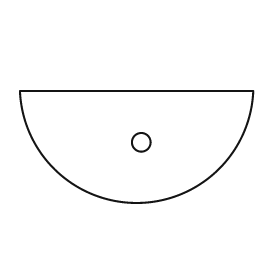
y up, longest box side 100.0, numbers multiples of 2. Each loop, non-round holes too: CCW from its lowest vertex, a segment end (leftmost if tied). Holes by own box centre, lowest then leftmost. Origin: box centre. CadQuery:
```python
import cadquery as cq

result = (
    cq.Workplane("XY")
    .moveTo(-50.0, 24.0)
    .threePointArc((0.0, -24.0), (50.0, 24.0))
    .close()
    .moveTo(2.0, 2.0)
    .circle(4.0)
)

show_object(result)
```